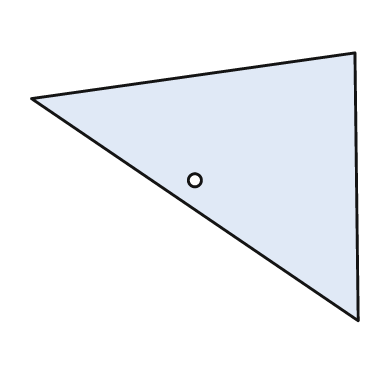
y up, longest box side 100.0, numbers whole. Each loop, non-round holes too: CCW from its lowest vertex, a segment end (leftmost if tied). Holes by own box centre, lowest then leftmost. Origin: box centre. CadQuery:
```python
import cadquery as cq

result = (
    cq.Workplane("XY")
    .moveTo(50.0, -41.0)
    .lineTo(49.0, 41.0)
    .lineTo(-50.0, 27.0)
    .close()
    .moveTo(0.0, 2.0)
    .circle(2.0)
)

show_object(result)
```